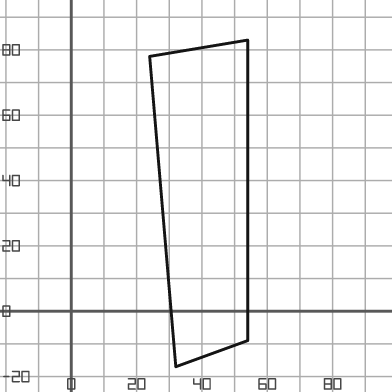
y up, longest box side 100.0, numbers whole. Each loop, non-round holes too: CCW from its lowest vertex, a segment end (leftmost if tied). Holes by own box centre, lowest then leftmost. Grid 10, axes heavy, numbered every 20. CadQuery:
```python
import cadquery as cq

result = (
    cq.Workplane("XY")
    .moveTo(32.0, -17.0)
    .lineTo(54.0, -9.0)
    .lineTo(54.0, 83.0)
    .lineTo(24.0, 78.0)
    .close()
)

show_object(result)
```